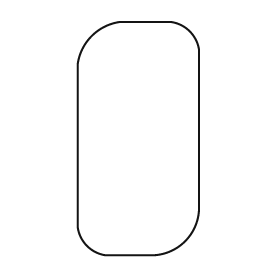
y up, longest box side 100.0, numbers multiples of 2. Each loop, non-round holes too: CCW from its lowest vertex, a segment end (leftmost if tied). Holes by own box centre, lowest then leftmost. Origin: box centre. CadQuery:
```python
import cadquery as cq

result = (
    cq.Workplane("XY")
    .moveTo(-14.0, -50.0)
    .lineTo(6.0, -50.0)
    .threePointArc((20.0, -44.0), (26.0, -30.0))
    .lineTo(26.0, 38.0)
    .threePointArc((22.0, 46.0), (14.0, 50.0))
    .lineTo(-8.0, 50.0)
    .threePointArc((-20.0, 44.0), (-26.0, 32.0))
    .lineTo(-26.0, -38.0)
    .threePointArc((-22.0, -46.0), (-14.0, -50.0))
    .close()
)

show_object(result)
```